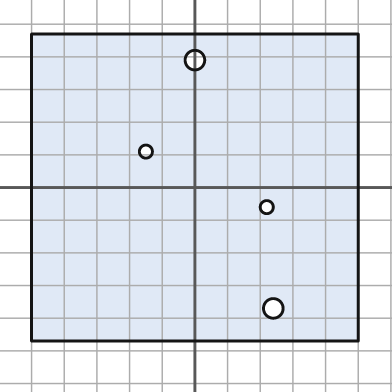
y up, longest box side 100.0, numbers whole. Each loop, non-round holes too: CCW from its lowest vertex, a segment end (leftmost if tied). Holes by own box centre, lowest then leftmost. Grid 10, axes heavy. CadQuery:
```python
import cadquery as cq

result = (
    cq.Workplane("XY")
    .moveTo(-50.0, -47.0)
    .lineTo(50.0, -47.0)
    .lineTo(50.0, 47.0)
    .lineTo(-50.0, 47.0)
    .close()
    .moveTo(24.0, -37.0)
    .circle(3.0)
    .moveTo(22.0, -6.0)
    .circle(2.0)
    .moveTo(-15.0, 11.0)
    .circle(2.0)
    .moveTo(0.0, 39.0)
    .circle(3.0)
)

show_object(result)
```